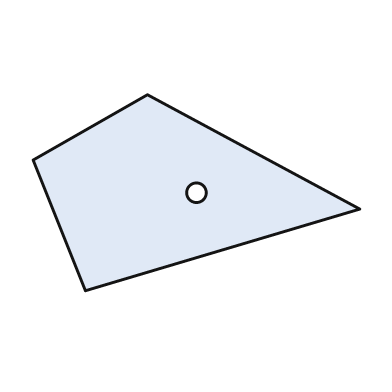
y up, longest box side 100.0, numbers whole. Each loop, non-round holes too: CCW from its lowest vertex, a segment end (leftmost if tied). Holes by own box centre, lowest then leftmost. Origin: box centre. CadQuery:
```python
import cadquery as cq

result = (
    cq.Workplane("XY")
    .moveTo(-34.0, -30.0)
    .lineTo(50.0, -5.0)
    .lineTo(-15.0, 30.0)
    .lineTo(-50.0, 10.0)
    .close()
    .moveTo(0.0, 0.0)
    .circle(3.0)
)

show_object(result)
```